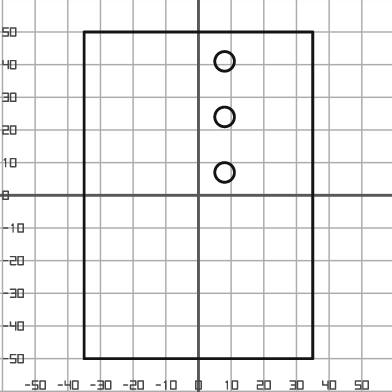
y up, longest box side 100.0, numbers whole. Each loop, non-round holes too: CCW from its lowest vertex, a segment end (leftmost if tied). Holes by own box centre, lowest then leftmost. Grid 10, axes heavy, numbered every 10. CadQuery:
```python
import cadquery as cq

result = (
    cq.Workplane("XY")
    .moveTo(-35.0, -50.0)
    .lineTo(35.0, -50.0)
    .lineTo(35.0, 50.0)
    .lineTo(-35.0, 50.0)
    .close()
    .moveTo(8.0, 7.0)
    .circle(3.0)
    .moveTo(8.0, 24.0)
    .circle(3.0)
    .moveTo(8.0, 41.0)
    .circle(3.0)
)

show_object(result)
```